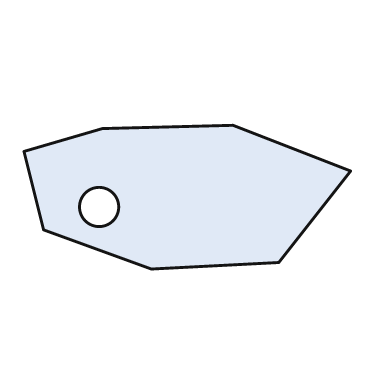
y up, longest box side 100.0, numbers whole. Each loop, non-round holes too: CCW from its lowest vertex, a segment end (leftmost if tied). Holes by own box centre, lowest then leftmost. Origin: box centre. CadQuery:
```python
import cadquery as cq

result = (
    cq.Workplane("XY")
    .moveTo(-11.0, -22.0)
    .lineTo(28.0, -20.0)
    .lineTo(50.0, 8.0)
    .lineTo(14.0, 22.0)
    .lineTo(-26.0, 21.0)
    .lineTo(-50.0, 14.0)
    .lineTo(-44.0, -10.0)
    .close()
    .moveTo(-27.0, -3.0)
    .circle(6.0)
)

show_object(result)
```